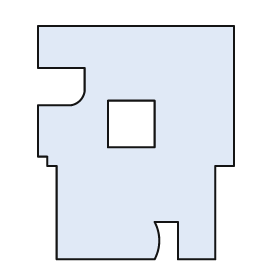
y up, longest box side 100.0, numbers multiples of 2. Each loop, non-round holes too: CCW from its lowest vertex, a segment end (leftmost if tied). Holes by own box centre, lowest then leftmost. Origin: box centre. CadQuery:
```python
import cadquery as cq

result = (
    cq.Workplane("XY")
    .moveTo(-34.0, -50.0)
    .lineTo(8.0, -50.0)
    .threePointArc((10.0, -42.0), (8.0, -34.0))
    .lineTo(18.0, -34.0)
    .lineTo(18.0, -50.0)
    .lineTo(34.0, -50.0)
    .lineTo(34.0, -10.0)
    .lineTo(42.0, -10.0)
    .lineTo(42.0, 50.0)
    .lineTo(-42.0, 50.0)
    .lineTo(-42.0, 32.0)
    .lineTo(-22.0, 32.0)
    .lineTo(-22.0, 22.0)
    .threePointArc((-24.0, 18.0), (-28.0, 16.0))
    .lineTo(-42.0, 16.0)
    .lineTo(-42.0, -6.0)
    .lineTo(-38.0, -6.0)
    .lineTo(-38.0, -10.0)
    .lineTo(-34.0, -10.0)
    .close()
    .moveTo(-12.0, -2.0)
    .lineTo(8.0, -2.0)
    .lineTo(8.0, 18.0)
    .lineTo(-12.0, 18.0)
    .close()
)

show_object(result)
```